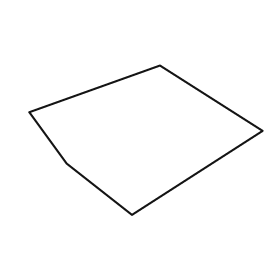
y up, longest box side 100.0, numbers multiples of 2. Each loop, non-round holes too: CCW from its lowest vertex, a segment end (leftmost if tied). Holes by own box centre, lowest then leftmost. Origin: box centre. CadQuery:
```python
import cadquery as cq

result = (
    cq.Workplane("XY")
    .moveTo(-6.0, -32.0)
    .lineTo(50.0, 4.0)
    .lineTo(6.0, 32.0)
    .lineTo(-50.0, 12.0)
    .lineTo(-34.0, -10.0)
    .close()
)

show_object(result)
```